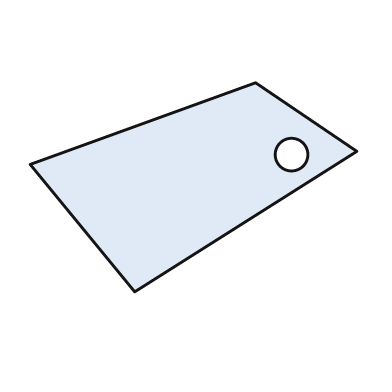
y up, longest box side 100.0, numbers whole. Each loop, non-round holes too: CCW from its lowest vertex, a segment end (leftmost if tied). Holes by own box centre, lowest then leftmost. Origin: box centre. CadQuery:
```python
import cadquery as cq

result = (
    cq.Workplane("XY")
    .moveTo(-18.0, -32.0)
    .lineTo(50.0, 11.0)
    .lineTo(19.0, 32.0)
    .lineTo(-50.0, 7.0)
    .close()
    .moveTo(30.0, 10.0)
    .circle(5.0)
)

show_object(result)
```